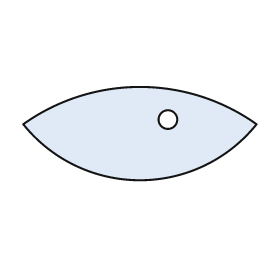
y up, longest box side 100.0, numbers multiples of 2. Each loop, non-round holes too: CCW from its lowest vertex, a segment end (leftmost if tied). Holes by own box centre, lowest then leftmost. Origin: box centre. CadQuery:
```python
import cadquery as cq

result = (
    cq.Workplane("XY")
    .moveTo(-50.0, 4.0)
    .threePointArc((0.0, -20.0), (50.0, 4.0))
    .threePointArc((0.0, 20.0), (-50.0, 4.0))
    .close()
    .moveTo(12.0, 6.0)
    .circle(4.0)
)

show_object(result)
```